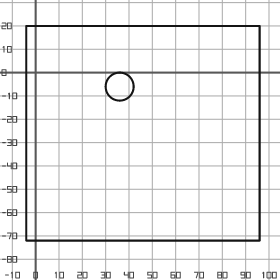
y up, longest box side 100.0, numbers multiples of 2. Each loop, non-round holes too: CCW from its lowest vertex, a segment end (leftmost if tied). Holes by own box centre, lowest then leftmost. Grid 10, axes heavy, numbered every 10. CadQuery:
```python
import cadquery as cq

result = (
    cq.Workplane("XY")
    .moveTo(-4.0, -72.0)
    .lineTo(96.0, -72.0)
    .lineTo(96.0, 20.0)
    .lineTo(-4.0, 20.0)
    .close()
    .moveTo(36.0, -6.0)
    .circle(6.0)
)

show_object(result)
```